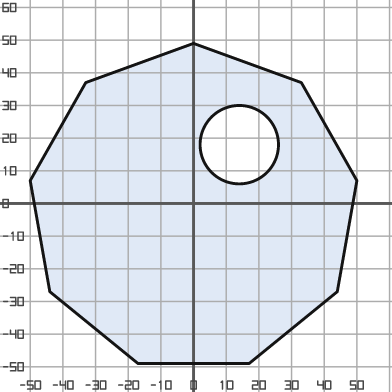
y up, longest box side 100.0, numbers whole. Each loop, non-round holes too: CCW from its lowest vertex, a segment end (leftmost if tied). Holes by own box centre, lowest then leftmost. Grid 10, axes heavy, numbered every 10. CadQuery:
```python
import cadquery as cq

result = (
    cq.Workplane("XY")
    .moveTo(-17.0, -49.0)
    .lineTo(17.0, -49.0)
    .lineTo(44.0, -27.0)
    .lineTo(50.0, 7.0)
    .lineTo(33.0, 37.0)
    .lineTo(0.0, 49.0)
    .lineTo(-33.0, 37.0)
    .lineTo(-50.0, 7.0)
    .lineTo(-44.0, -27.0)
    .close()
    .moveTo(14.0, 18.0)
    .circle(12.0)
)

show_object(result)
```